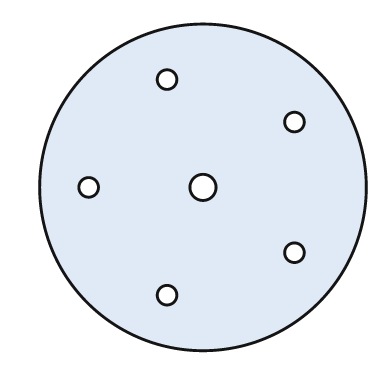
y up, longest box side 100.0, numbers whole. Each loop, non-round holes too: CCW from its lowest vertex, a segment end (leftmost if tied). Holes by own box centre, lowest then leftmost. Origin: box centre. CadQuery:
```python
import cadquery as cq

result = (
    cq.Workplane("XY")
    .moveTo(0.0, 0.0)
    .circle(50.0)
    .moveTo(-11.0, -33.0)
    .circle(3.0)
    .moveTo(28.0, -20.0)
    .circle(3.0)
    .moveTo(-35.0, 0.0)
    .circle(3.0)
    .moveTo(0.0, 0.0)
    .circle(4.0)
    .moveTo(28.0, 20.0)
    .circle(3.0)
    .moveTo(-11.0, 33.0)
    .circle(3.0)
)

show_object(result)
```